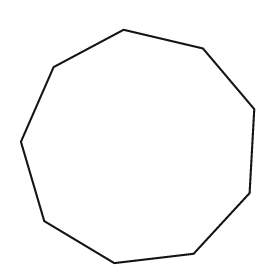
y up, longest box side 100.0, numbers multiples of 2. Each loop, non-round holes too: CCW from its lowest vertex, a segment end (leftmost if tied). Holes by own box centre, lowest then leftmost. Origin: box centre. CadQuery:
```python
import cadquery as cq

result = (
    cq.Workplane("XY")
    .moveTo(-10.0, -50.0)
    .lineTo(24.0, -46.0)
    .lineTo(48.0, -20.0)
    .lineTo(50.0, 16.0)
    .lineTo(28.0, 42.0)
    .lineTo(-6.0, 50.0)
    .lineTo(-36.0, 34.0)
    .lineTo(-50.0, 2.0)
    .lineTo(-40.0, -32.0)
    .close()
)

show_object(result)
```